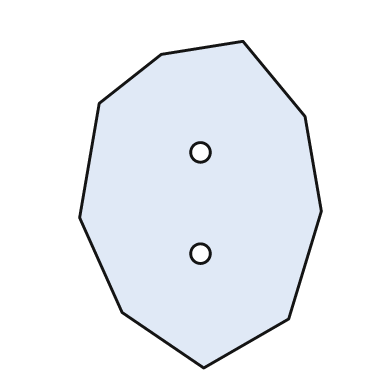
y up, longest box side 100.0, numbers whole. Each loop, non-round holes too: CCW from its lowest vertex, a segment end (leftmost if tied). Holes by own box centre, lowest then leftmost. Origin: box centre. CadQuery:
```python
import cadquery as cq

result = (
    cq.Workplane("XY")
    .moveTo(1.0, -50.0)
    .lineTo(27.0, -35.0)
    .lineTo(37.0, -2.0)
    .lineTo(32.0, 27.0)
    .lineTo(13.0, 50.0)
    .lineTo(-12.0, 46.0)
    .lineTo(-31.0, 31.0)
    .lineTo(-37.0, -4.0)
    .lineTo(-24.0, -33.0)
    .close()
    .moveTo(0.0, -15.0)
    .circle(3.0)
    .moveTo(0.0, 16.0)
    .circle(3.0)
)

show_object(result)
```